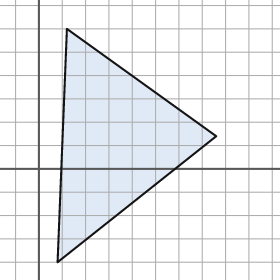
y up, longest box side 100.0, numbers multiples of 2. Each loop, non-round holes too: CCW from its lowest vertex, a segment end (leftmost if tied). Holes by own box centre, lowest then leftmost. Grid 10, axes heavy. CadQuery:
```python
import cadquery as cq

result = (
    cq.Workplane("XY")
    .moveTo(8.0, -40.0)
    .lineTo(76.0, 14.0)
    .lineTo(12.0, 60.0)
    .close()
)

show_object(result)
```